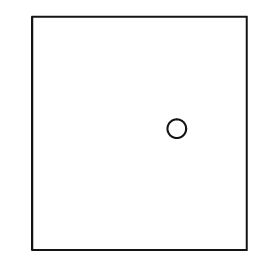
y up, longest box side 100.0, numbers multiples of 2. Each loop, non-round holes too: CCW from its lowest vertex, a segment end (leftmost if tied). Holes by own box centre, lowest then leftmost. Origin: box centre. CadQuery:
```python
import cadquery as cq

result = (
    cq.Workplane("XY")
    .moveTo(-46.0, -50.0)
    .lineTo(46.0, -50.0)
    .lineTo(46.0, 50.0)
    .lineTo(-46.0, 50.0)
    .close()
    .moveTo(16.0, 2.0)
    .circle(4.0)
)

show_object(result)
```